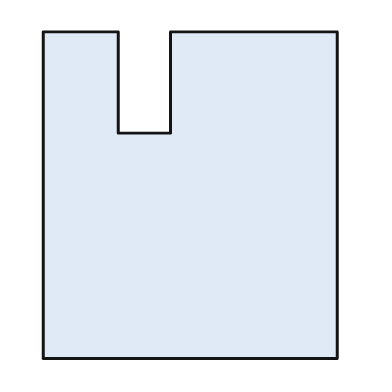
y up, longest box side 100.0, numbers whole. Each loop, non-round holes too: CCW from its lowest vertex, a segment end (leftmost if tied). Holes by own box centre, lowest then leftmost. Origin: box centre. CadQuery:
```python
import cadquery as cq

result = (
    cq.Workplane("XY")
    .moveTo(-45.0, -50.0)
    .lineTo(45.0, -50.0)
    .lineTo(45.0, 50.0)
    .lineTo(-6.0, 50.0)
    .lineTo(-6.0, 19.0)
    .lineTo(-22.0, 19.0)
    .lineTo(-22.0, 50.0)
    .lineTo(-45.0, 50.0)
    .close()
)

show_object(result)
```